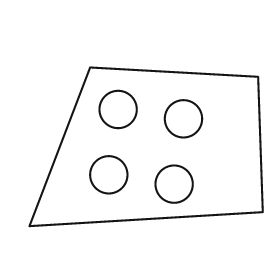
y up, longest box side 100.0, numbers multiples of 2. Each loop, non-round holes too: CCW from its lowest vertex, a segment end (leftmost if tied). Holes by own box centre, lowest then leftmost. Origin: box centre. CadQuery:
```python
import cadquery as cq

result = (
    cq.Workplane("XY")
    .moveTo(-50.0, -34.0)
    .lineTo(50.0, -28.0)
    .lineTo(48.0, 30.0)
    .lineTo(-24.0, 34.0)
    .close()
    .moveTo(12.0, -16.0)
    .circle(8.0)
    .moveTo(-16.0, -12.0)
    .circle(8.0)
    .moveTo(16.0, 12.0)
    .circle(8.0)
    .moveTo(-12.0, 16.0)
    .circle(8.0)
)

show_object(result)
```